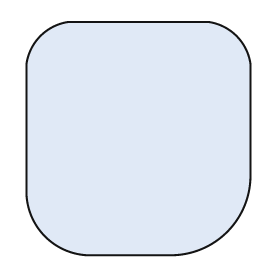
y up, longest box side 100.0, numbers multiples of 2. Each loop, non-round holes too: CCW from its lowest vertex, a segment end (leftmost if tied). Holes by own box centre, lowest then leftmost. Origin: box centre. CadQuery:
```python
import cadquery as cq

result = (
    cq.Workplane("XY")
    .moveTo(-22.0, -50.0)
    .lineTo(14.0, -50.0)
    .threePointArc((38.0, -40.0), (48.0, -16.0))
    .lineTo(48.0, 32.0)
    .threePointArc((42.0, 44.0), (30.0, 50.0))
    .lineTo(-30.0, 50.0)
    .threePointArc((-42.0, 44.0), (-48.0, 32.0))
    .lineTo(-48.0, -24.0)
    .threePointArc((-40.0, -42.0), (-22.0, -50.0))
    .close()
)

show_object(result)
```